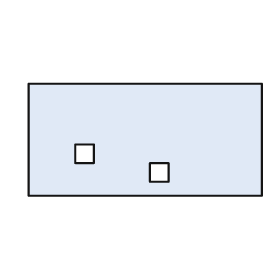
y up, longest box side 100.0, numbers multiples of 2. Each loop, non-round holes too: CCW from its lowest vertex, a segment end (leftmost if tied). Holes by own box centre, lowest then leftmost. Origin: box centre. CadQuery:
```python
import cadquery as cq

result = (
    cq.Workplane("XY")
    .moveTo(-50.0, -24.0)
    .lineTo(50.0, -24.0)
    .lineTo(50.0, 24.0)
    .lineTo(-50.0, 24.0)
    .close()
    .moveTo(2.0, -18.0)
    .lineTo(10.0, -18.0)
    .lineTo(10.0, -10.0)
    .lineTo(2.0, -10.0)
    .close()
    .moveTo(-30.0, -10.0)
    .lineTo(-22.0, -10.0)
    .lineTo(-22.0, -2.0)
    .lineTo(-30.0, -2.0)
    .close()
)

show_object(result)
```